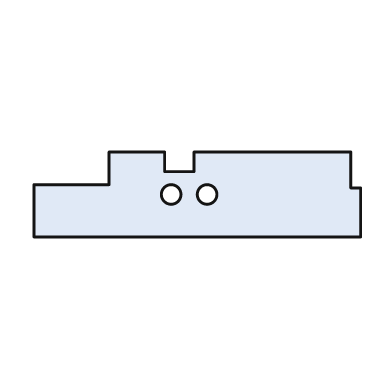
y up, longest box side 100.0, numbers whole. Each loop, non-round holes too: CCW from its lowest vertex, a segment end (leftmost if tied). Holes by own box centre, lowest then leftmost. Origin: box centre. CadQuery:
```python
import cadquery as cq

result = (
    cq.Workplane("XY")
    .moveTo(-50.0, -13.0)
    .lineTo(50.0, -13.0)
    .lineTo(50.0, 2.0)
    .lineTo(47.0, 2.0)
    .lineTo(47.0, 13.0)
    .lineTo(-1.0, 13.0)
    .lineTo(-1.0, 7.0)
    .lineTo(-10.0, 7.0)
    .lineTo(-10.0, 13.0)
    .lineTo(-27.0, 13.0)
    .lineTo(-27.0, 3.0)
    .lineTo(-50.0, 3.0)
    .close()
    .moveTo(-8.0, 0.0)
    .circle(3.0)
    .moveTo(3.0, 0.0)
    .circle(3.0)
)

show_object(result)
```